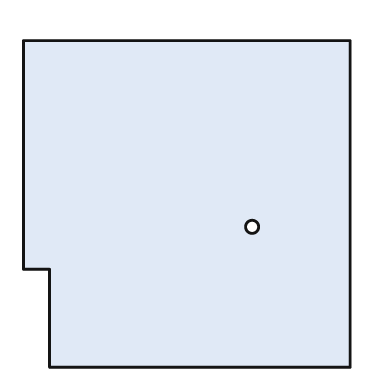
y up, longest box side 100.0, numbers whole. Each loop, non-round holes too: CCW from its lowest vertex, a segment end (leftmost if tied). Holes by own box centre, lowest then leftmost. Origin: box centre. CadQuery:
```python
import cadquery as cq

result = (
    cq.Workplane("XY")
    .moveTo(-42.0, -50.0)
    .lineTo(50.0, -50.0)
    .lineTo(50.0, 50.0)
    .lineTo(-50.0, 50.0)
    .lineTo(-50.0, -20.0)
    .lineTo(-42.0, -20.0)
    .close()
    .moveTo(20.0, -7.0)
    .circle(2.0)
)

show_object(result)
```